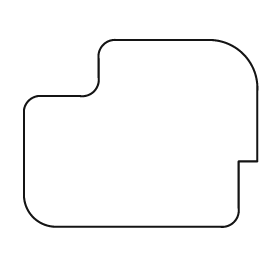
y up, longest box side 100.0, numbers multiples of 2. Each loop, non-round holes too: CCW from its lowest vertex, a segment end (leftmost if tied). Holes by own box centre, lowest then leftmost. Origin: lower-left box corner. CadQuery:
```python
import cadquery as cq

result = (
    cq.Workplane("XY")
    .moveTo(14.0, 0.0)
    .lineTo(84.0, 0.0)
    .threePointArc((90.0, 2.0), (92.0, 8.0))
    .lineTo(92.0, 28.0)
    .lineTo(100.0, 28.0)
    .lineTo(100.0, 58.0)
    .threePointArc((94.0, 74.0), (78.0, 80.0))
    .lineTo(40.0, 80.0)
    .threePointArc((34.0, 78.0), (32.0, 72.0))
    .lineTo(32.0, 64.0)
    .threePointArc((30.0, 58.0), (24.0, 56.0))
    .lineTo(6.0, 56.0)
    .threePointArc((2.0, 54.0), (0.0, 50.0))
    .lineTo(0.0, 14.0)
    .threePointArc((4.0, 4.0), (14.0, 0.0))
    .close()
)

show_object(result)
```